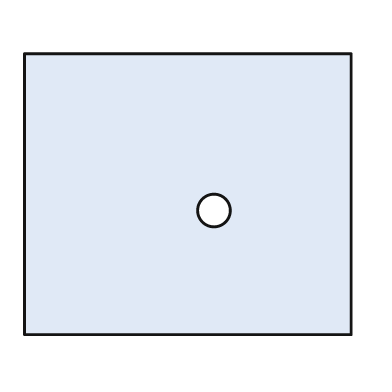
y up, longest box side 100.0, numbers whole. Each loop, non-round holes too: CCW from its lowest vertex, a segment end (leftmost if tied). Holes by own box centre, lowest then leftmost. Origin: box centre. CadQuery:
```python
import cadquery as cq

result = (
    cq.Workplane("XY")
    .moveTo(-50.0, -43.0)
    .lineTo(50.0, -43.0)
    .lineTo(50.0, 43.0)
    .lineTo(-50.0, 43.0)
    .close()
    .moveTo(8.0, -5.0)
    .circle(5.0)
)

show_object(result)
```